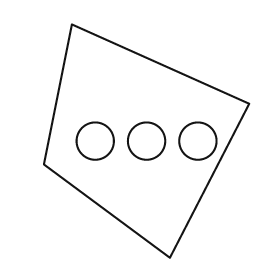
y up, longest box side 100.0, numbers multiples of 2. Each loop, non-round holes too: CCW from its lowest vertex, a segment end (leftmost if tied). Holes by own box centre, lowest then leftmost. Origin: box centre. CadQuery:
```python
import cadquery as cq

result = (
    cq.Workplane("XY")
    .moveTo(10.0, -50.0)
    .lineTo(44.0, 16.0)
    .lineTo(-32.0, 50.0)
    .lineTo(-44.0, -10.0)
    .close()
    .moveTo(-22.0, 0.0)
    .circle(8.0)
    .moveTo(0.0, 0.0)
    .circle(8.0)
    .moveTo(22.0, 0.0)
    .circle(8.0)
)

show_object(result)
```